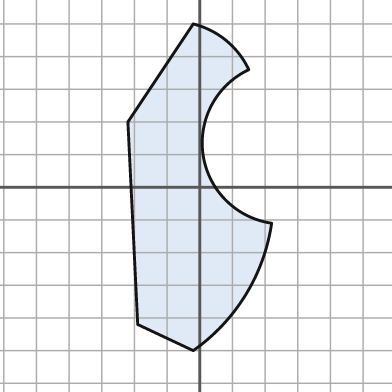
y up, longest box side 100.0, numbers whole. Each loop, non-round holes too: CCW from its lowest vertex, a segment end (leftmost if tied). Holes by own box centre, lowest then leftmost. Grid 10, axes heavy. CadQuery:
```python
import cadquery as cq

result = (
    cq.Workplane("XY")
    .moveTo(-2.0, -50.0)
    .threePointArc((14.0, -33.0), (22.0, -11.0))
    .threePointArc((1.0, 10.0), (15.0, 36.0))
    .threePointArc((8.0, 45.0), (-2.0, 50.0))
    .lineTo(-22.0, 20.0)
    .lineTo(-19.0, -42.0)
    .close()
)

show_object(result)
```